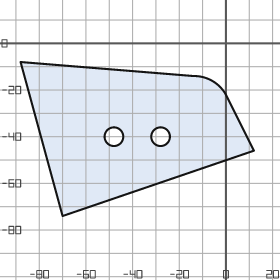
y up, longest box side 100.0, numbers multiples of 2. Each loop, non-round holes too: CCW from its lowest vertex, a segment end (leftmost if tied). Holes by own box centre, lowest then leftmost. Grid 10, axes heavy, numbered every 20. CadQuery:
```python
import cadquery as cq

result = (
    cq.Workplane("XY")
    .moveTo(-70.0, -74.0)
    .lineTo(12.0, -46.0)
    .lineTo(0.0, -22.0)
    .threePointArc((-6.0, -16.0), (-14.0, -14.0))
    .lineTo(-88.0, -8.0)
    .close()
    .moveTo(-48.0, -40.0)
    .circle(4.0)
    .moveTo(-28.0, -40.0)
    .circle(4.0)
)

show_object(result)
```